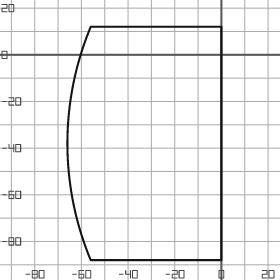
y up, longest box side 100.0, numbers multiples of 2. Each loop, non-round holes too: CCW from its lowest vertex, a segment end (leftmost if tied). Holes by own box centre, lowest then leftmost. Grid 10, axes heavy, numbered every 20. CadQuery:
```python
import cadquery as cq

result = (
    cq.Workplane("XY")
    .moveTo(-56.0, -88.0)
    .lineTo(0.0, -88.0)
    .lineTo(0.0, 12.0)
    .lineTo(-56.0, 12.0)
    .threePointArc((-66.0, -38.0), (-56.0, -88.0))
    .close()
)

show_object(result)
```